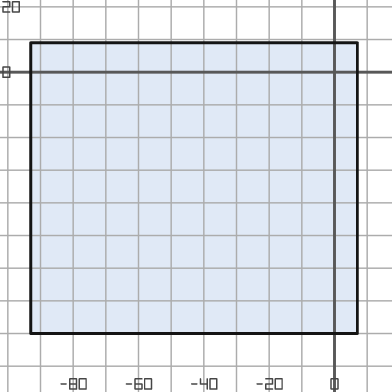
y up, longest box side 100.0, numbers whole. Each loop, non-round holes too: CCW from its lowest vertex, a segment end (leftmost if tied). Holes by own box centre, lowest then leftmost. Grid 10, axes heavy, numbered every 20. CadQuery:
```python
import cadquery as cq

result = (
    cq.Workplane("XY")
    .moveTo(-93.0, -80.0)
    .lineTo(7.0, -80.0)
    .lineTo(7.0, 9.0)
    .lineTo(-93.0, 9.0)
    .close()
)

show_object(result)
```